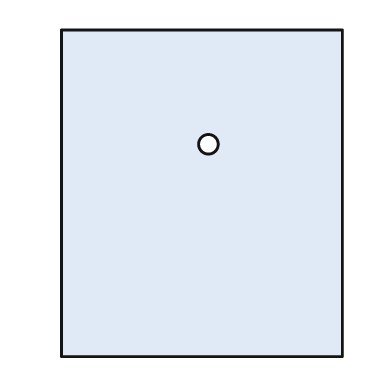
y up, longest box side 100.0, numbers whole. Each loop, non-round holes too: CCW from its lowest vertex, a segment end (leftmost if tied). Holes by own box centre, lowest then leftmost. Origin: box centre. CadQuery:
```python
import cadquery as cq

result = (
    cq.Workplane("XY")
    .moveTo(-43.0, -50.0)
    .lineTo(43.0, -50.0)
    .lineTo(43.0, 50.0)
    .lineTo(-43.0, 50.0)
    .close()
    .moveTo(2.0, 15.0)
    .circle(3.0)
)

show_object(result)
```